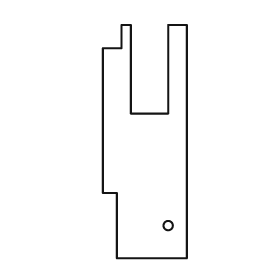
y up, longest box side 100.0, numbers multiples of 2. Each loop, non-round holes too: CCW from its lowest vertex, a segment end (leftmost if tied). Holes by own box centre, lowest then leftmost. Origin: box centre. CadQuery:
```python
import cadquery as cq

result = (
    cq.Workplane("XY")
    .moveTo(-12.0, -50.0)
    .lineTo(18.0, -50.0)
    .lineTo(18.0, 50.0)
    .lineTo(10.0, 50.0)
    .lineTo(10.0, 12.0)
    .lineTo(-6.0, 12.0)
    .lineTo(-6.0, 50.0)
    .lineTo(-10.0, 50.0)
    .lineTo(-10.0, 40.0)
    .lineTo(-18.0, 40.0)
    .lineTo(-18.0, -22.0)
    .lineTo(-12.0, -22.0)
    .close()
    .moveTo(10.0, -36.0)
    .circle(2.0)
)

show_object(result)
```